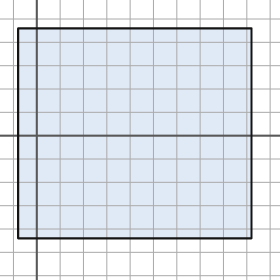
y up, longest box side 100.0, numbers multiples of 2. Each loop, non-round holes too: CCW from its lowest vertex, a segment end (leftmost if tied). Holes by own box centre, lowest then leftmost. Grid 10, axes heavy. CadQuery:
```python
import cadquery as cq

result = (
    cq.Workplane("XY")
    .moveTo(-8.0, -44.0)
    .lineTo(92.0, -44.0)
    .lineTo(92.0, 46.0)
    .lineTo(-8.0, 46.0)
    .close()
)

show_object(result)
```